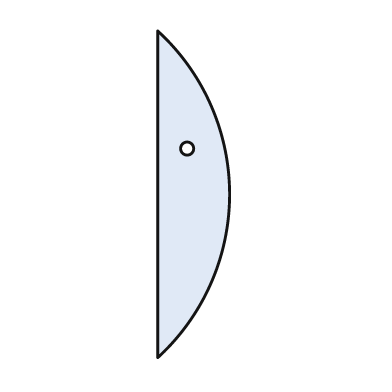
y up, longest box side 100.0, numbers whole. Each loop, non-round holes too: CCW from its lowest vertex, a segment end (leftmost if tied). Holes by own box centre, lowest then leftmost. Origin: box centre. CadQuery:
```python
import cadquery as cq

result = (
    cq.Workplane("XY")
    .moveTo(-11.0, -50.0)
    .threePointArc((11.0, 0.0), (-11.0, 50.0))
    .close()
    .moveTo(-2.0, 14.0)
    .circle(2.0)
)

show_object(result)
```